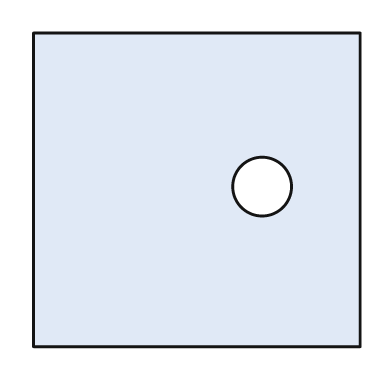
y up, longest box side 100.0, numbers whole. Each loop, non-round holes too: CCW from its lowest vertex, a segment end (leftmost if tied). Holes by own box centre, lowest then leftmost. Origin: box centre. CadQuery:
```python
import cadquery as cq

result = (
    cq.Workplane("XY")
    .moveTo(-50.0, -48.0)
    .lineTo(50.0, -48.0)
    .lineTo(50.0, 48.0)
    .lineTo(-50.0, 48.0)
    .close()
    .moveTo(20.0, 1.0)
    .circle(9.0)
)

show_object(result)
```